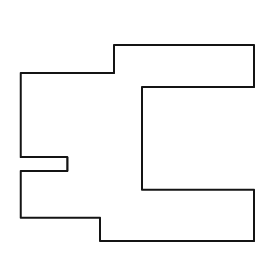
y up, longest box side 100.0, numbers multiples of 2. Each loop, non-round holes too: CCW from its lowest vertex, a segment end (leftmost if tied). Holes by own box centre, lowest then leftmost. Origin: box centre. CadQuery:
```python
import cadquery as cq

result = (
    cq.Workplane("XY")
    .moveTo(-16.0, -42.0)
    .lineTo(50.0, -42.0)
    .lineTo(50.0, -20.0)
    .lineTo(2.0, -20.0)
    .lineTo(2.0, 24.0)
    .lineTo(50.0, 24.0)
    .lineTo(50.0, 42.0)
    .lineTo(-10.0, 42.0)
    .lineTo(-10.0, 30.0)
    .lineTo(-50.0, 30.0)
    .lineTo(-50.0, -6.0)
    .lineTo(-30.0, -6.0)
    .lineTo(-30.0, -12.0)
    .lineTo(-50.0, -12.0)
    .lineTo(-50.0, -32.0)
    .lineTo(-16.0, -32.0)
    .close()
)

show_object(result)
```